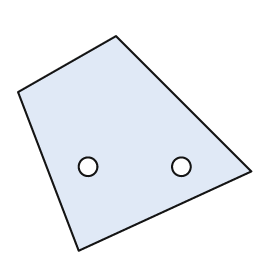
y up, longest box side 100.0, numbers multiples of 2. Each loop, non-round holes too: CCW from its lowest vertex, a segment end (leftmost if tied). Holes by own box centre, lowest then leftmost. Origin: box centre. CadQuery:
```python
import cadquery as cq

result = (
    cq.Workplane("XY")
    .moveTo(-24.0, -46.0)
    .lineTo(50.0, -12.0)
    .lineTo(-8.0, 46.0)
    .lineTo(-50.0, 22.0)
    .close()
    .moveTo(-20.0, -10.0)
    .circle(4.0)
    .moveTo(20.0, -10.0)
    .circle(4.0)
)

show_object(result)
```